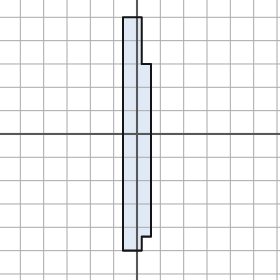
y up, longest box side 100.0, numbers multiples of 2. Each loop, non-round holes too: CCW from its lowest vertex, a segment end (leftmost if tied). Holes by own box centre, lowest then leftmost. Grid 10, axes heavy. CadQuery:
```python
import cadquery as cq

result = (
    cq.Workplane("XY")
    .moveTo(-6.0, -50.0)
    .lineTo(2.0, -50.0)
    .lineTo(2.0, -44.0)
    .lineTo(6.0, -44.0)
    .lineTo(6.0, 30.0)
    .lineTo(2.0, 30.0)
    .lineTo(2.0, 50.0)
    .lineTo(-6.0, 50.0)
    .close()
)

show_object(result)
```